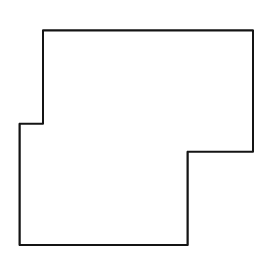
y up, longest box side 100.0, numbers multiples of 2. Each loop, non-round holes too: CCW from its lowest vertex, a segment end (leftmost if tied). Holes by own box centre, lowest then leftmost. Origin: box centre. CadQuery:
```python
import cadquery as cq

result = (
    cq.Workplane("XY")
    .moveTo(-50.0, -46.0)
    .lineTo(22.0, -46.0)
    .lineTo(22.0, -6.0)
    .lineTo(50.0, -6.0)
    .lineTo(50.0, 46.0)
    .lineTo(-40.0, 46.0)
    .lineTo(-40.0, 6.0)
    .lineTo(-50.0, 6.0)
    .close()
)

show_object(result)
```